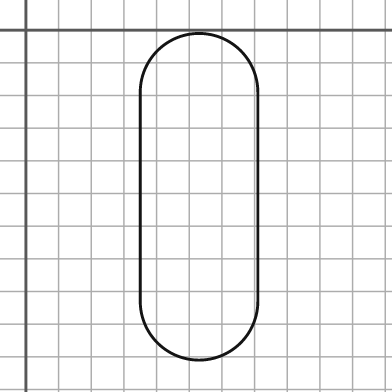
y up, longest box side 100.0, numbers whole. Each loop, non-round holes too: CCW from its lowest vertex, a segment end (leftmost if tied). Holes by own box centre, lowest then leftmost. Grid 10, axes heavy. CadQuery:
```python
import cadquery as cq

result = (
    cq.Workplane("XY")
    .moveTo(35.0, -83.0)
    .threePointArc((53.0, -101.0), (71.0, -83.0))
    .lineTo(71.0, -19.0)
    .threePointArc((53.0, -1.0), (35.0, -19.0))
    .close()
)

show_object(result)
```